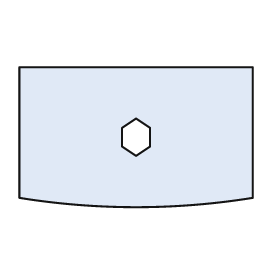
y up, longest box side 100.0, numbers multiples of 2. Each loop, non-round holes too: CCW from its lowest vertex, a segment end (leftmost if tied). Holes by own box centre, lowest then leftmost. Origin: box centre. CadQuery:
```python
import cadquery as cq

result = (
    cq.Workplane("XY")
    .moveTo(-50.0, -26.0)
    .threePointArc((0.0, -30.0), (50.0, -26.0))
    .lineTo(50.0, 30.0)
    .lineTo(-50.0, 30.0)
    .close()
    .moveTo(0.0, -8.0)
    .lineTo(6.0, -4.0)
    .lineTo(6.0, 4.0)
    .lineTo(0.0, 8.0)
    .lineTo(-6.0, 4.0)
    .lineTo(-6.0, -4.0)
    .close()
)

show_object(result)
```